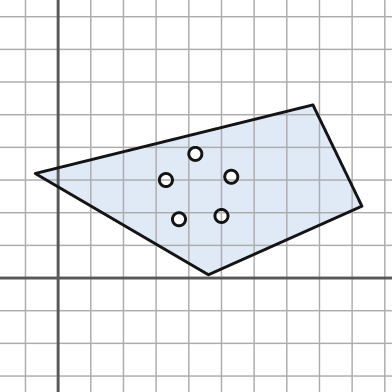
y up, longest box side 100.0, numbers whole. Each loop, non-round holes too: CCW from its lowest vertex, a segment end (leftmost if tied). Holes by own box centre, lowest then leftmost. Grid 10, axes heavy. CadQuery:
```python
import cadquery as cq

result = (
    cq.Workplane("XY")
    .moveTo(46.0, 1.0)
    .lineTo(93.0, 22.0)
    .lineTo(78.0, 53.0)
    .lineTo(-7.0, 32.0)
    .close()
    .moveTo(37.0, 18.0)
    .circle(2.0)
    .moveTo(50.0, 19.0)
    .circle(2.0)
    .moveTo(33.0, 30.0)
    .circle(2.0)
    .moveTo(53.0, 31.0)
    .circle(2.0)
    .moveTo(42.0, 38.0)
    .circle(2.0)
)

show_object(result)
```